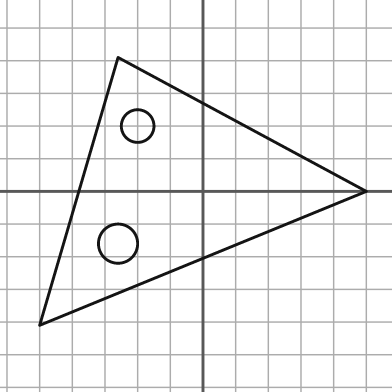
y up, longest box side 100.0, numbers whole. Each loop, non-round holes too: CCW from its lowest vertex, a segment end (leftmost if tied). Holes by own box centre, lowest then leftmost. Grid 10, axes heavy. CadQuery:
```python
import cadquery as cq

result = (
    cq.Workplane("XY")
    .moveTo(-50.0, -41.0)
    .lineTo(50.0, 0.0)
    .lineTo(-26.0, 41.0)
    .close()
    .moveTo(-26.0, -16.0)
    .circle(6.0)
    .moveTo(-20.0, 20.0)
    .circle(5.0)
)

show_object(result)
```